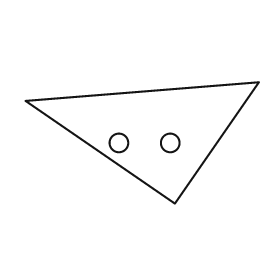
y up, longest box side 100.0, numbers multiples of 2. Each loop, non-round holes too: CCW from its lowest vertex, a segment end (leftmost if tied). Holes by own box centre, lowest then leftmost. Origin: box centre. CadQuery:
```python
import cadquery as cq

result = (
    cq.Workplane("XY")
    .moveTo(14.0, -26.0)
    .lineTo(50.0, 26.0)
    .lineTo(-50.0, 18.0)
    .close()
    .moveTo(-10.0, 0.0)
    .circle(4.0)
    .moveTo(12.0, 0.0)
    .circle(4.0)
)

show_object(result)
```